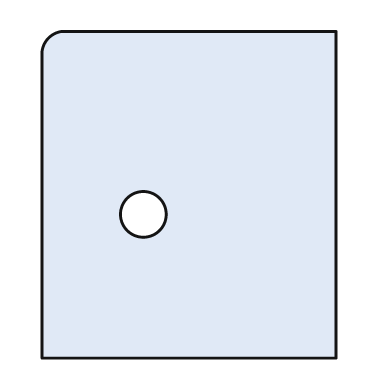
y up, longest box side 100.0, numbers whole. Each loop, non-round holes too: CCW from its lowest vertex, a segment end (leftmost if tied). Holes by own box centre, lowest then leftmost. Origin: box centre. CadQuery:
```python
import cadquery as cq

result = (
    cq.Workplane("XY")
    .moveTo(-45.0, -50.0)
    .lineTo(45.0, -50.0)
    .lineTo(45.0, 50.0)
    .lineTo(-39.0, 50.0)
    .threePointArc((-43.0, 48.0), (-45.0, 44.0))
    .close()
    .moveTo(-14.0, -6.0)
    .circle(7.0)
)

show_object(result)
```